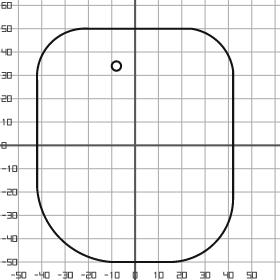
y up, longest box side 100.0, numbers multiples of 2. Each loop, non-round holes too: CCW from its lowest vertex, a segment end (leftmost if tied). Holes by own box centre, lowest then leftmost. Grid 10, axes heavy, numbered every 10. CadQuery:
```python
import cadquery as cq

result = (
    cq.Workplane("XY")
    .moveTo(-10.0, -50.0)
    .lineTo(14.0, -50.0)
    .threePointArc((34.0, -42.0), (42.0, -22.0))
    .lineTo(42.0, 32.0)
    .threePointArc((36.0, 44.0), (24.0, 50.0))
    .lineTo(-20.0, 50.0)
    .threePointArc((-36.0, 44.0), (-42.0, 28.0))
    .lineTo(-42.0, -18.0)
    .threePointArc((-32.0, -40.0), (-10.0, -50.0))
    .close()
    .moveTo(-8.0, 34.0)
    .circle(2.0)
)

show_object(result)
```